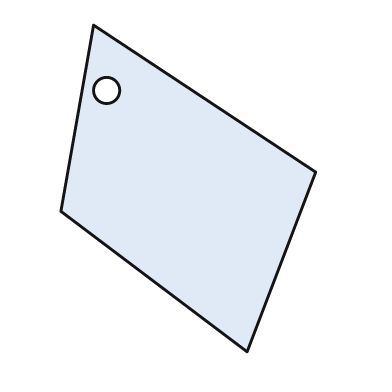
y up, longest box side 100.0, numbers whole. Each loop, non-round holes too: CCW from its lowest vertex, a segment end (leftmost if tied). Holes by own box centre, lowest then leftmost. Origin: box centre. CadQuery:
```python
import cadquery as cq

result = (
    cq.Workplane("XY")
    .moveTo(18.0, -50.0)
    .lineTo(39.0, 5.0)
    .lineTo(-29.0, 50.0)
    .lineTo(-39.0, -7.0)
    .close()
    .moveTo(-25.0, 30.0)
    .circle(4.0)
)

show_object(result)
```